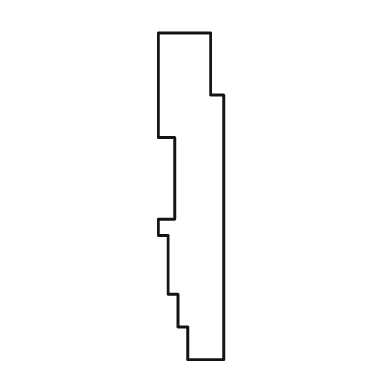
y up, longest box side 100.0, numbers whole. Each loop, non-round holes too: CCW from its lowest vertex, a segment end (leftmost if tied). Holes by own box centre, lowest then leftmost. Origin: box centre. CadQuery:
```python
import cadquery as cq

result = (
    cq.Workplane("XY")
    .moveTo(-1.0, -50.0)
    .lineTo(10.0, -50.0)
    .lineTo(10.0, 31.0)
    .lineTo(6.0, 31.0)
    .lineTo(6.0, 50.0)
    .lineTo(-10.0, 50.0)
    .lineTo(-10.0, 18.0)
    .lineTo(-5.0, 18.0)
    .lineTo(-5.0, -7.0)
    .lineTo(-10.0, -7.0)
    .lineTo(-10.0, -12.0)
    .lineTo(-7.0, -12.0)
    .lineTo(-7.0, -30.0)
    .lineTo(-4.0, -30.0)
    .lineTo(-4.0, -40.0)
    .lineTo(-1.0, -40.0)
    .close()
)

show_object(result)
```